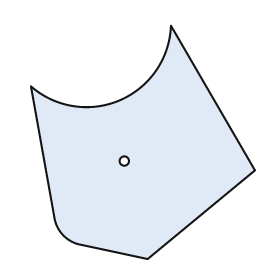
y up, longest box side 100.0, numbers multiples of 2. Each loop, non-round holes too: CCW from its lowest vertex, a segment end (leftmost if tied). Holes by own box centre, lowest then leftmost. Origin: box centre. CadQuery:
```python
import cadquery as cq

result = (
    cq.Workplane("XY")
    .moveTo(2.0, -50.0)
    .lineTo(48.0, -12.0)
    .lineTo(12.0, 50.0)
    .threePointArc((-10.0, 18.0), (-48.0, 24.0))
    .lineTo(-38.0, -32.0)
    .threePointArc((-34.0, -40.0), (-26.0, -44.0))
    .close()
    .moveTo(-8.0, -8.0)
    .circle(2.0)
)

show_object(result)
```